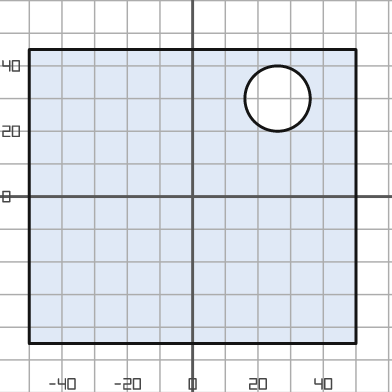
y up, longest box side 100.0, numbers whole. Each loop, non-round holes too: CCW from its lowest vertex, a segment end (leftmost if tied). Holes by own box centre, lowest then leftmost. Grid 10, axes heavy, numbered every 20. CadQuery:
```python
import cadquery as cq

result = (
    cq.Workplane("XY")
    .moveTo(-50.0, -45.0)
    .lineTo(50.0, -45.0)
    .lineTo(50.0, 45.0)
    .lineTo(-50.0, 45.0)
    .close()
    .moveTo(26.0, 30.0)
    .circle(10.0)
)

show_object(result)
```